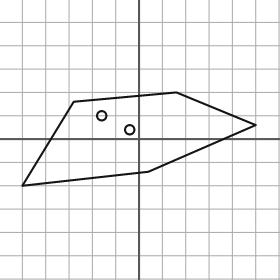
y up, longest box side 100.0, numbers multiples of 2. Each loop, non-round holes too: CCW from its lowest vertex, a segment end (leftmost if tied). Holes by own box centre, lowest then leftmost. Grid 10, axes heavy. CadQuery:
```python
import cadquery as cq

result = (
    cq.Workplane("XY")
    .moveTo(-50.0, -20.0)
    .lineTo(4.0, -14.0)
    .lineTo(50.0, 6.0)
    .lineTo(16.0, 20.0)
    .lineTo(-28.0, 16.0)
    .close()
    .moveTo(-4.0, 4.0)
    .circle(2.0)
    .moveTo(-16.0, 10.0)
    .circle(2.0)
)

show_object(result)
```